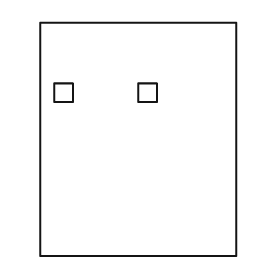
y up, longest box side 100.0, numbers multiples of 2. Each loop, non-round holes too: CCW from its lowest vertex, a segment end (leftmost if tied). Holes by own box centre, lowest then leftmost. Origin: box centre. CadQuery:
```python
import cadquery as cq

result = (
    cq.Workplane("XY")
    .moveTo(-42.0, -50.0)
    .lineTo(42.0, -50.0)
    .lineTo(42.0, 50.0)
    .lineTo(-42.0, 50.0)
    .close()
    .moveTo(-36.0, 16.0)
    .lineTo(-28.0, 16.0)
    .lineTo(-28.0, 24.0)
    .lineTo(-36.0, 24.0)
    .close()
    .moveTo(0.0, 16.0)
    .lineTo(8.0, 16.0)
    .lineTo(8.0, 24.0)
    .lineTo(0.0, 24.0)
    .close()
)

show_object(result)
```